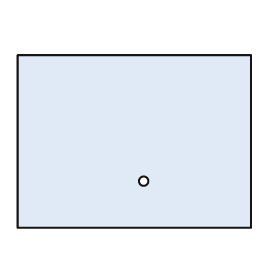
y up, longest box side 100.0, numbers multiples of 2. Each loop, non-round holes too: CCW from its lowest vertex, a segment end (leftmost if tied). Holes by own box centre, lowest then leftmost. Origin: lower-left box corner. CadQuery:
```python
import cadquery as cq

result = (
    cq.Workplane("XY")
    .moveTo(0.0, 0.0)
    .lineTo(100.0, 0.0)
    .lineTo(100.0, 74.0)
    .lineTo(0.0, 74.0)
    .close()
    .moveTo(54.0, 20.0)
    .circle(2.0)
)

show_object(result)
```